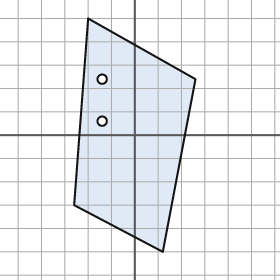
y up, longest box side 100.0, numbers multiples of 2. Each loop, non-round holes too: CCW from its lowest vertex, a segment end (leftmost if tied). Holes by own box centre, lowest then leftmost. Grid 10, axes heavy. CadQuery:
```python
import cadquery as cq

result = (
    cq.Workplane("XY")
    .moveTo(12.0, -50.0)
    .lineTo(26.0, 24.0)
    .lineTo(-20.0, 50.0)
    .lineTo(-26.0, -30.0)
    .close()
    .moveTo(-14.0, 6.0)
    .circle(2.0)
    .moveTo(-14.0, 24.0)
    .circle(2.0)
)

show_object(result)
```